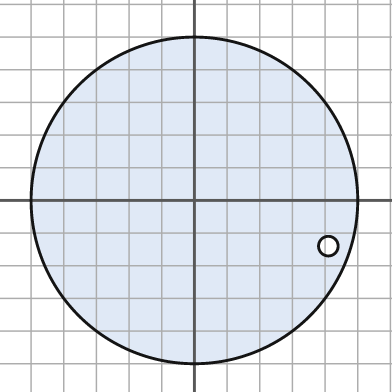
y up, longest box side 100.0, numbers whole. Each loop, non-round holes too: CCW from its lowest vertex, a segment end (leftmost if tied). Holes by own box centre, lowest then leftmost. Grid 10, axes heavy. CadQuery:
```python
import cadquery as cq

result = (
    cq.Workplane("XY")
    .moveTo(0.0, 0.0)
    .circle(50.0)
    .moveTo(41.0, -14.0)
    .circle(3.0)
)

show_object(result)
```